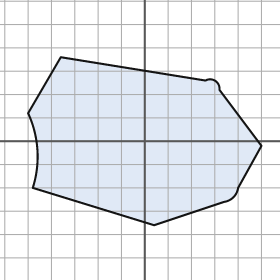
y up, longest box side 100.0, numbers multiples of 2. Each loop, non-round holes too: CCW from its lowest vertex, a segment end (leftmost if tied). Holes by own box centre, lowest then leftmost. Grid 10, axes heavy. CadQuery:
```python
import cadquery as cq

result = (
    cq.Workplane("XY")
    .moveTo(4.0, -36.0)
    .lineTo(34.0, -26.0)
    .threePointArc((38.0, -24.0), (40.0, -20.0))
    .lineTo(50.0, -2.0)
    .lineTo(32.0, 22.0)
    .threePointArc((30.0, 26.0), (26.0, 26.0))
    .lineTo(-36.0, 36.0)
    .lineTo(-50.0, 12.0)
    .threePointArc((-46.0, -4.0), (-48.0, -20.0))
    .close()
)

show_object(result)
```